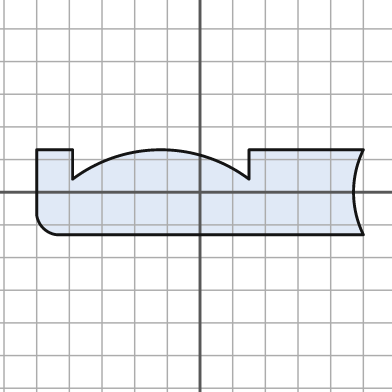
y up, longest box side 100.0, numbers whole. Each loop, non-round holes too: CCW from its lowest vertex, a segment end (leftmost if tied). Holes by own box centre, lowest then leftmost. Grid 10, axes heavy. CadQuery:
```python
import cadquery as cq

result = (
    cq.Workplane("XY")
    .moveTo(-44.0, -13.0)
    .lineTo(50.0, -13.0)
    .threePointArc((47.0, 0.0), (50.0, 13.0))
    .lineTo(15.0, 13.0)
    .lineTo(15.0, 4.0)
    .threePointArc((-12.0, 13.0), (-39.0, 4.0))
    .lineTo(-39.0, 13.0)
    .lineTo(-50.0, 13.0)
    .lineTo(-50.0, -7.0)
    .threePointArc((-48.0, -11.0), (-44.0, -13.0))
    .close()
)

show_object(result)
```